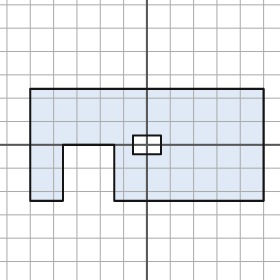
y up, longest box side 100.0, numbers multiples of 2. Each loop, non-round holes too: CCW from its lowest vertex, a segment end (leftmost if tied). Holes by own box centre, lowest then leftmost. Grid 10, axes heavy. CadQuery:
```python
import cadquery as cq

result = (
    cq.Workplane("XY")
    .moveTo(-50.0, -24.0)
    .lineTo(-36.0, -24.0)
    .lineTo(-36.0, 0.0)
    .lineTo(-14.0, 0.0)
    .lineTo(-14.0, -24.0)
    .lineTo(50.0, -24.0)
    .lineTo(50.0, 24.0)
    .lineTo(-50.0, 24.0)
    .close()
    .moveTo(-6.0, -4.0)
    .lineTo(6.0, -4.0)
    .lineTo(6.0, 4.0)
    .lineTo(-6.0, 4.0)
    .close()
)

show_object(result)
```